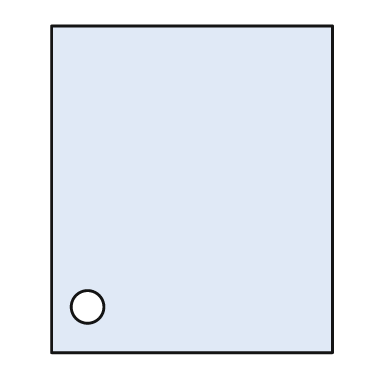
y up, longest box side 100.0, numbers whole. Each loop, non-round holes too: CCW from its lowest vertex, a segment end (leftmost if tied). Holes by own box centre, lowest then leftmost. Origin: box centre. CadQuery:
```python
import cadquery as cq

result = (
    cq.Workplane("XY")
    .moveTo(-43.0, -50.0)
    .lineTo(43.0, -50.0)
    .lineTo(43.0, 50.0)
    .lineTo(-43.0, 50.0)
    .close()
    .moveTo(-32.0, -36.0)
    .circle(5.0)
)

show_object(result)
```